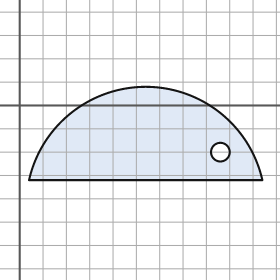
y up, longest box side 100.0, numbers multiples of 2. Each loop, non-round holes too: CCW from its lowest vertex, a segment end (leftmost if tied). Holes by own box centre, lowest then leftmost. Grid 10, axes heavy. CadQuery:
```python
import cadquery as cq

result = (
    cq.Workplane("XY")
    .moveTo(4.0, -32.0)
    .lineTo(104.0, -32.0)
    .threePointArc((54.0, 8.0), (4.0, -32.0))
    .close()
    .moveTo(86.0, -20.0)
    .circle(4.0)
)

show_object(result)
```